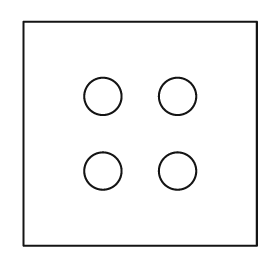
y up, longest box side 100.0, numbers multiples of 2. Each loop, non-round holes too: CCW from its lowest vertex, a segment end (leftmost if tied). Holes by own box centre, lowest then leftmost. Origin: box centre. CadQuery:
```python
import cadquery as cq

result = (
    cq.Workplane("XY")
    .moveTo(-50.0, -48.0)
    .lineTo(50.0, -48.0)
    .lineTo(50.0, 48.0)
    .lineTo(-50.0, 48.0)
    .close()
    .moveTo(-16.0, -16.0)
    .circle(8.0)
    .moveTo(16.0, -16.0)
    .circle(8.0)
    .moveTo(-16.0, 16.0)
    .circle(8.0)
    .moveTo(16.0, 16.0)
    .circle(8.0)
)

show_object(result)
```